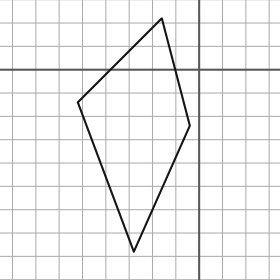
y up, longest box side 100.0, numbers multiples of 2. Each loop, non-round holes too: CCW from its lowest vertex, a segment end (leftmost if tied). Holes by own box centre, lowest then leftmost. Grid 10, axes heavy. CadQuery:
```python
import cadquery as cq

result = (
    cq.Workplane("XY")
    .moveTo(-28.0, -78.0)
    .lineTo(-4.0, -24.0)
    .lineTo(-16.0, 22.0)
    .lineTo(-52.0, -14.0)
    .close()
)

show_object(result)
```